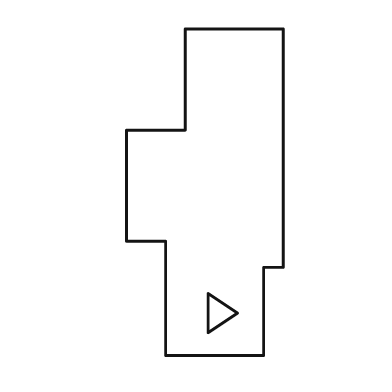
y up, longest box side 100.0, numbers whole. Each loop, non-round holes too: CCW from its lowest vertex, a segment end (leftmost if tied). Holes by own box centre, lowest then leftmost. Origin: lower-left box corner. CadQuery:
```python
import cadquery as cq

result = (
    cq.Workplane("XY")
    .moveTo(12.0, 0.0)
    .lineTo(42.0, 0.0)
    .lineTo(42.0, 27.0)
    .lineTo(48.0, 27.0)
    .lineTo(48.0, 100.0)
    .lineTo(18.0, 100.0)
    .lineTo(18.0, 69.0)
    .lineTo(0.0, 69.0)
    .lineTo(0.0, 35.0)
    .lineTo(12.0, 35.0)
    .close()
    .moveTo(25.0, 7.0)
    .lineTo(34.0, 13.0)
    .lineTo(25.0, 19.0)
    .close()
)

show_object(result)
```